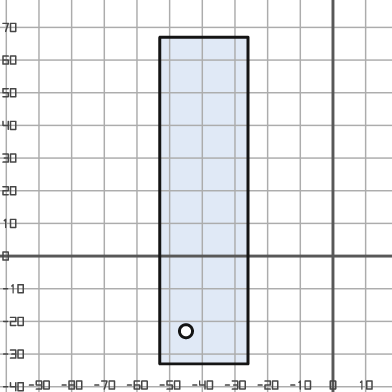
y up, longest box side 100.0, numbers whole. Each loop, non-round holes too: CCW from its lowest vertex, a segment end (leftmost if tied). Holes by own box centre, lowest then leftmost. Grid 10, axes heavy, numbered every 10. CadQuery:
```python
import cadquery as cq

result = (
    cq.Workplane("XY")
    .moveTo(-53.0, -33.0)
    .lineTo(-26.0, -33.0)
    .lineTo(-26.0, 67.0)
    .lineTo(-53.0, 67.0)
    .close()
    .moveTo(-45.0, -23.0)
    .circle(2.0)
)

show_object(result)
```